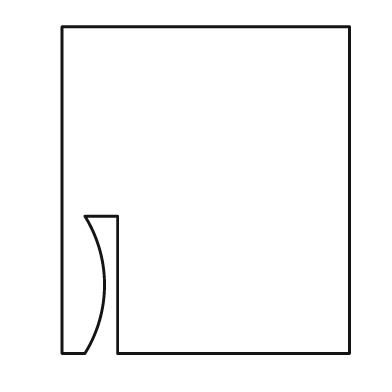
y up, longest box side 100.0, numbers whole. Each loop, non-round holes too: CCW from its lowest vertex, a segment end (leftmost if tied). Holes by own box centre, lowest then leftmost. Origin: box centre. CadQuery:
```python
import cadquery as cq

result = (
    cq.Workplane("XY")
    .moveTo(-44.0, -50.0)
    .lineTo(-37.0, -50.0)
    .threePointArc((-31.0, -29.0), (-37.0, -8.0))
    .lineTo(-27.0, -8.0)
    .lineTo(-27.0, -50.0)
    .lineTo(44.0, -50.0)
    .lineTo(44.0, 50.0)
    .lineTo(-44.0, 50.0)
    .close()
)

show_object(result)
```